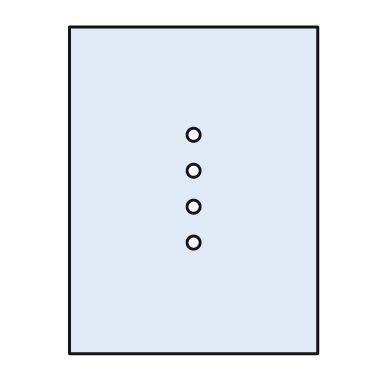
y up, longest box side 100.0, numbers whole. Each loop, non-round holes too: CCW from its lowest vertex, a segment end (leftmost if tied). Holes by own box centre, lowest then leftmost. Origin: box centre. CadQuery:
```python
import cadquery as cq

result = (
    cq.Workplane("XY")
    .moveTo(-38.0, -50.0)
    .lineTo(38.0, -50.0)
    .lineTo(38.0, 50.0)
    .lineTo(-38.0, 50.0)
    .close()
    .moveTo(0.0, -16.0)
    .circle(2.0)
    .moveTo(0.0, -5.0)
    .circle(2.0)
    .moveTo(0.0, 6.0)
    .circle(2.0)
    .moveTo(0.0, 17.0)
    .circle(2.0)
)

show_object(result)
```